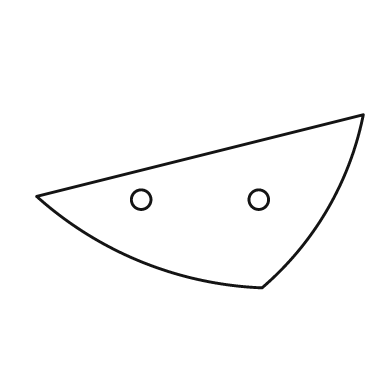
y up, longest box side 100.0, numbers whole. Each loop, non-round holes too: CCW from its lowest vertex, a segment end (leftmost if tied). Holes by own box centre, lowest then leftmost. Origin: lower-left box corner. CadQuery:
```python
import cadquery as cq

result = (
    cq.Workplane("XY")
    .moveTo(69.0, 0.0)
    .threePointArc((89.0, 24.0), (100.0, 53.0))
    .lineTo(0.0, 28.0)
    .threePointArc((32.0, 8.0), (69.0, 0.0))
    .close()
    .moveTo(32.0, 27.0)
    .circle(3.0)
    .moveTo(68.0, 27.0)
    .circle(3.0)
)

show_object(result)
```